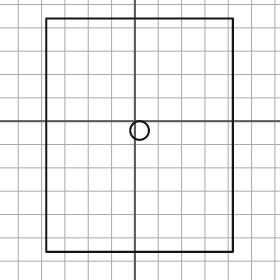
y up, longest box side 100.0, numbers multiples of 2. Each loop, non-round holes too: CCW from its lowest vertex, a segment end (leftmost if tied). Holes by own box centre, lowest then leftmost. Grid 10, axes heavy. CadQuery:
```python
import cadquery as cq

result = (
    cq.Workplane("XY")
    .moveTo(-38.0, -56.0)
    .lineTo(42.0, -56.0)
    .lineTo(42.0, 44.0)
    .lineTo(-38.0, 44.0)
    .close()
    .moveTo(2.0, -4.0)
    .circle(4.0)
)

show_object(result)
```